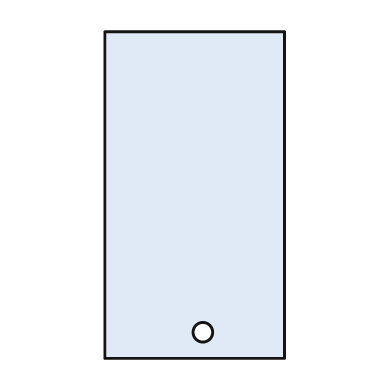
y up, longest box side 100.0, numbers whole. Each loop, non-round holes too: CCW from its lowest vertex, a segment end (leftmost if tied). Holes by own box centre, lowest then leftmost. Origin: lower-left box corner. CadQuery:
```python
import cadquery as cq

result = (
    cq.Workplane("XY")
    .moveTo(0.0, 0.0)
    .lineTo(55.0, 0.0)
    .lineTo(55.0, 100.0)
    .lineTo(0.0, 100.0)
    .close()
    .moveTo(30.0, 8.0)
    .circle(3.0)
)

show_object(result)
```